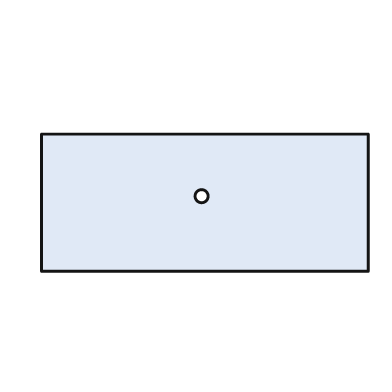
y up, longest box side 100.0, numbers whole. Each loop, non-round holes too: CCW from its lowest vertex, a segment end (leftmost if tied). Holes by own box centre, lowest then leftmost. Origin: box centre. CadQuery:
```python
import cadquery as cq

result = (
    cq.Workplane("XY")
    .moveTo(-50.0, -21.0)
    .lineTo(50.0, -21.0)
    .lineTo(50.0, 21.0)
    .lineTo(-50.0, 21.0)
    .close()
    .moveTo(-1.0, 2.0)
    .circle(2.0)
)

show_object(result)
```